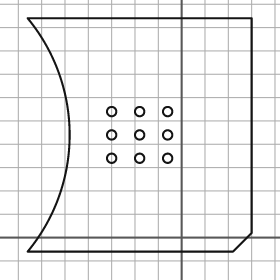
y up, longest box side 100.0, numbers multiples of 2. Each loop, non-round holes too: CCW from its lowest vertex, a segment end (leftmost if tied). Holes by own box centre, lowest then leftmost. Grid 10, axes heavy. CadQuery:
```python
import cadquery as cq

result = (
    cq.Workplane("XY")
    .moveTo(-66.0, -6.0)
    .lineTo(22.0, -6.0)
    .lineTo(30.0, 2.0)
    .lineTo(30.0, 94.0)
    .lineTo(-66.0, 94.0)
    .threePointArc((-48.0, 44.0), (-66.0, -6.0))
    .close()
    .moveTo(-30.0, 34.0)
    .circle(2.0)
    .moveTo(-18.0, 34.0)
    .circle(2.0)
    .moveTo(-6.0, 34.0)
    .circle(2.0)
    .moveTo(-30.0, 44.0)
    .circle(2.0)
    .moveTo(-18.0, 44.0)
    .circle(2.0)
    .moveTo(-6.0, 44.0)
    .circle(2.0)
    .moveTo(-30.0, 54.0)
    .circle(2.0)
    .moveTo(-18.0, 54.0)
    .circle(2.0)
    .moveTo(-6.0, 54.0)
    .circle(2.0)
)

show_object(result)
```